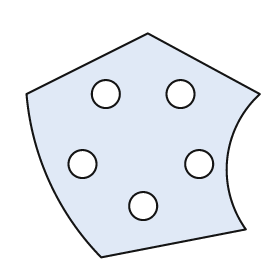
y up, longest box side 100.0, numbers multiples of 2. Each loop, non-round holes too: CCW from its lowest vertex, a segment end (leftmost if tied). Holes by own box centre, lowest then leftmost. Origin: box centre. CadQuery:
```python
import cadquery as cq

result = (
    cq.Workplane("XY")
    .moveTo(-18.0, -48.0)
    .lineTo(44.0, -36.0)
    .threePointArc((36.0, -6.0), (50.0, 22.0))
    .lineTo(2.0, 48.0)
    .lineTo(-50.0, 22.0)
    .threePointArc((-40.0, -16.0), (-18.0, -48.0))
    .close()
    .moveTo(0.0, -26.0)
    .circle(6.0)
    .moveTo(-26.0, -8.0)
    .circle(6.0)
    .moveTo(24.0, -8.0)
    .circle(6.0)
    .moveTo(-16.0, 22.0)
    .circle(6.0)
    .moveTo(16.0, 22.0)
    .circle(6.0)
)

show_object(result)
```